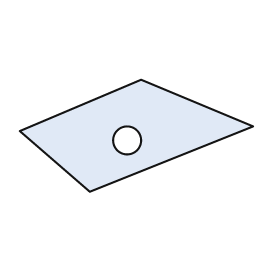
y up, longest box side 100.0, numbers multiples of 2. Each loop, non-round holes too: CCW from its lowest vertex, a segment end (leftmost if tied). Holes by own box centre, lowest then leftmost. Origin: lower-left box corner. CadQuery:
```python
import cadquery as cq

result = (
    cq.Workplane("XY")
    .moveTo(30.0, 0.0)
    .lineTo(100.0, 28.0)
    .lineTo(52.0, 48.0)
    .lineTo(0.0, 26.0)
    .close()
    .moveTo(46.0, 22.0)
    .circle(6.0)
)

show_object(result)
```